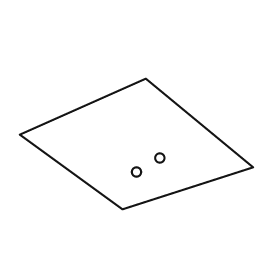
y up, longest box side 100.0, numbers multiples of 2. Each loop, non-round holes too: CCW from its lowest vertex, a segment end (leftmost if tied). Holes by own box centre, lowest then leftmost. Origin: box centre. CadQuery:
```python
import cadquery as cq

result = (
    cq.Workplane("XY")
    .moveTo(-6.0, -28.0)
    .lineTo(50.0, -10.0)
    .lineTo(4.0, 28.0)
    .lineTo(-50.0, 4.0)
    .close()
    .moveTo(0.0, -12.0)
    .circle(2.0)
    .moveTo(10.0, -6.0)
    .circle(2.0)
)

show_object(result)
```